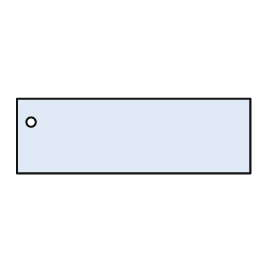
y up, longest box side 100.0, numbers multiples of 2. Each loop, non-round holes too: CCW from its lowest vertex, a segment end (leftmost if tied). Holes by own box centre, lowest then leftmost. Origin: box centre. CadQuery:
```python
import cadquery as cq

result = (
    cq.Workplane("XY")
    .moveTo(-50.0, -16.0)
    .lineTo(50.0, -16.0)
    .lineTo(50.0, 16.0)
    .lineTo(-50.0, 16.0)
    .close()
    .moveTo(-44.0, 6.0)
    .circle(2.0)
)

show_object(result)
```